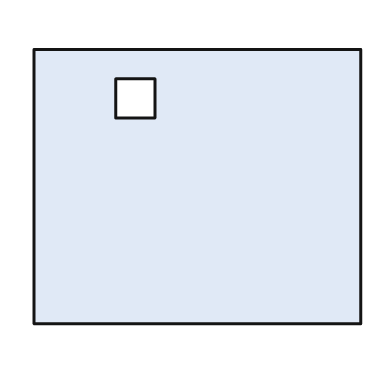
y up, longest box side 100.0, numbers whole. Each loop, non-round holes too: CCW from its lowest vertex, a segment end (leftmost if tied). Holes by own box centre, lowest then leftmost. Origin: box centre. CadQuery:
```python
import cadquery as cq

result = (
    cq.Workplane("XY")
    .moveTo(-50.0, -42.0)
    .lineTo(50.0, -42.0)
    .lineTo(50.0, 42.0)
    .lineTo(-50.0, 42.0)
    .close()
    .moveTo(-25.0, 21.0)
    .lineTo(-13.0, 21.0)
    .lineTo(-13.0, 33.0)
    .lineTo(-25.0, 33.0)
    .close()
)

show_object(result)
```